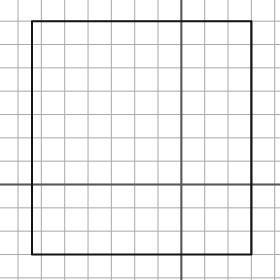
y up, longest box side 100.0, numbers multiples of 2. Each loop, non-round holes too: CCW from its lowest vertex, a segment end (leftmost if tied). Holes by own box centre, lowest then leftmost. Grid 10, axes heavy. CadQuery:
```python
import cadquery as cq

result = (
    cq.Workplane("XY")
    .moveTo(-64.0, -30.0)
    .lineTo(30.0, -30.0)
    .lineTo(30.0, 70.0)
    .lineTo(-64.0, 70.0)
    .close()
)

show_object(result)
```